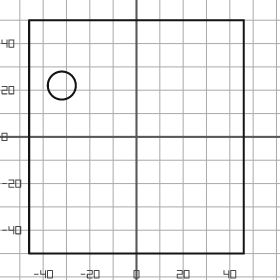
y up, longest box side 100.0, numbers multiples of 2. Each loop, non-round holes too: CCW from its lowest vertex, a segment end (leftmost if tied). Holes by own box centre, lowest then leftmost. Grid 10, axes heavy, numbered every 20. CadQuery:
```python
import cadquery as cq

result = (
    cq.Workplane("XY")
    .moveTo(-46.0, -50.0)
    .lineTo(46.0, -50.0)
    .lineTo(46.0, 50.0)
    .lineTo(-46.0, 50.0)
    .close()
    .moveTo(-32.0, 22.0)
    .circle(6.0)
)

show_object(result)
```